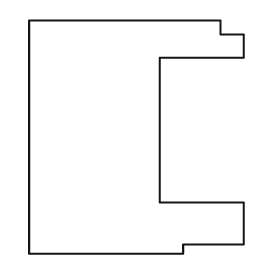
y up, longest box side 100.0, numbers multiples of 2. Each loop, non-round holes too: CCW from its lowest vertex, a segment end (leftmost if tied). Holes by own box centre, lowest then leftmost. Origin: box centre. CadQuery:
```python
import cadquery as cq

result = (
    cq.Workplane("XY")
    .moveTo(-46.0, -50.0)
    .lineTo(20.0, -50.0)
    .lineTo(20.0, -46.0)
    .lineTo(46.0, -46.0)
    .lineTo(46.0, -28.0)
    .lineTo(10.0, -28.0)
    .lineTo(10.0, 34.0)
    .lineTo(46.0, 34.0)
    .lineTo(46.0, 44.0)
    .lineTo(36.0, 44.0)
    .lineTo(36.0, 50.0)
    .lineTo(-46.0, 50.0)
    .close()
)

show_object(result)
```